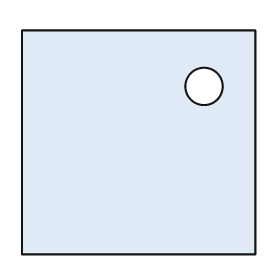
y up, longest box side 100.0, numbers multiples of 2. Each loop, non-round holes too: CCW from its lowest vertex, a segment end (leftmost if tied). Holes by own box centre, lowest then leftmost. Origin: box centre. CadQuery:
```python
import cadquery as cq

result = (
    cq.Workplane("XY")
    .moveTo(-50.0, -48.0)
    .lineTo(50.0, -48.0)
    .lineTo(50.0, 48.0)
    .lineTo(-50.0, 48.0)
    .close()
    .moveTo(28.0, 24.0)
    .circle(8.0)
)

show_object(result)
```